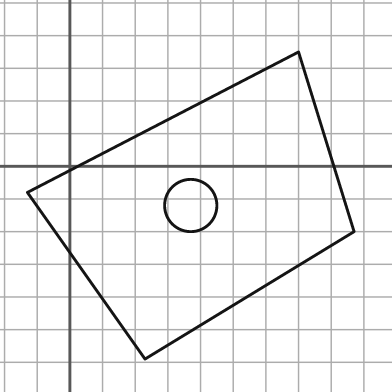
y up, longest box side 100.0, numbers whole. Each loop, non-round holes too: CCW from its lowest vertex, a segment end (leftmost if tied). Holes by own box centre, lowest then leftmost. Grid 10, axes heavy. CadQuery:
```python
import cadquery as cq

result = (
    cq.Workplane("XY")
    .moveTo(23.0, -59.0)
    .lineTo(87.0, -20.0)
    .lineTo(70.0, 35.0)
    .lineTo(-13.0, -8.0)
    .close()
    .moveTo(37.0, -12.0)
    .circle(8.0)
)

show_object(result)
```